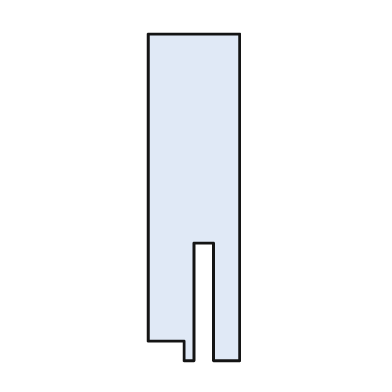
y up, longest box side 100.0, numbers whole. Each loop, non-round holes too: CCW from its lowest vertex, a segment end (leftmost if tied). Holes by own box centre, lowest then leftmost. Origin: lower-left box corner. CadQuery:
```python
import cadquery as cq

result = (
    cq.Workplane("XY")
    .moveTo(11.0, 0.0)
    .lineTo(14.0, 0.0)
    .lineTo(14.0, 36.0)
    .lineTo(20.0, 36.0)
    .lineTo(20.0, 0.0)
    .lineTo(28.0, 0.0)
    .lineTo(28.0, 100.0)
    .lineTo(0.0, 100.0)
    .lineTo(0.0, 6.0)
    .lineTo(11.0, 6.0)
    .close()
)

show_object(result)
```